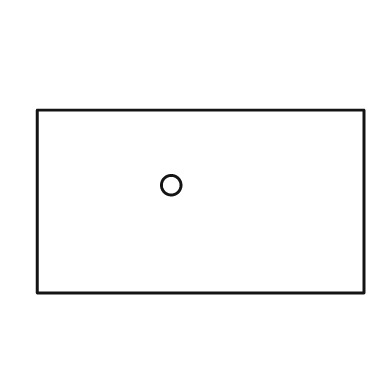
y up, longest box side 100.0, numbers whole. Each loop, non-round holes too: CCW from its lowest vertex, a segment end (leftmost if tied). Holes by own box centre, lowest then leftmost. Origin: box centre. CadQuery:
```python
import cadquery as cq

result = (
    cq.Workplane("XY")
    .moveTo(-50.0, -28.0)
    .lineTo(50.0, -28.0)
    .lineTo(50.0, 28.0)
    .lineTo(-50.0, 28.0)
    .close()
    .moveTo(-9.0, 5.0)
    .circle(3.0)
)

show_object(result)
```